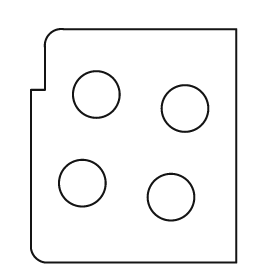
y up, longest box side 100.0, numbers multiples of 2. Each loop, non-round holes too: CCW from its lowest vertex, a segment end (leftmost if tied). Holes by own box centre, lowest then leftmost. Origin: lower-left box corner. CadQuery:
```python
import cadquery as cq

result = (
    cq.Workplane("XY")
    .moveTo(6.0, 0.0)
    .lineTo(88.0, 0.0)
    .lineTo(88.0, 100.0)
    .lineTo(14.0, 100.0)
    .threePointArc((8.0, 98.0), (6.0, 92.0))
    .lineTo(6.0, 74.0)
    .lineTo(0.0, 74.0)
    .lineTo(0.0, 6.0)
    .threePointArc((2.0, 2.0), (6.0, 0.0))
    .close()
    .moveTo(60.0, 28.0)
    .circle(10.0)
    .moveTo(22.0, 34.0)
    .circle(10.0)
    .moveTo(66.0, 66.0)
    .circle(10.0)
    .moveTo(28.0, 72.0)
    .circle(10.0)
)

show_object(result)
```